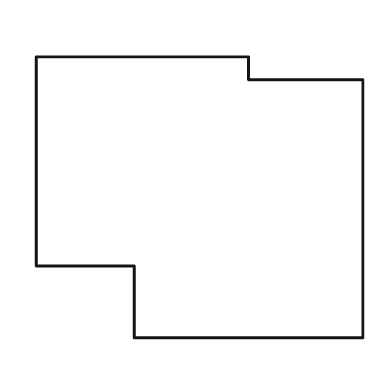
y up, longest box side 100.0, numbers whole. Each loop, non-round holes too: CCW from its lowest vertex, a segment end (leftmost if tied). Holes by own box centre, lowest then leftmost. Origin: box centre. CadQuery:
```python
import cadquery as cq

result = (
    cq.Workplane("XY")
    .moveTo(-20.0, -43.0)
    .lineTo(50.0, -43.0)
    .lineTo(50.0, 36.0)
    .lineTo(15.0, 36.0)
    .lineTo(15.0, 43.0)
    .lineTo(-50.0, 43.0)
    .lineTo(-50.0, -21.0)
    .lineTo(-20.0, -21.0)
    .close()
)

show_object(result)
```